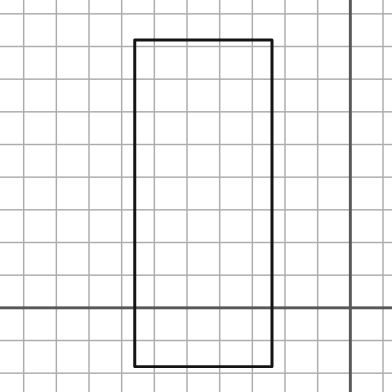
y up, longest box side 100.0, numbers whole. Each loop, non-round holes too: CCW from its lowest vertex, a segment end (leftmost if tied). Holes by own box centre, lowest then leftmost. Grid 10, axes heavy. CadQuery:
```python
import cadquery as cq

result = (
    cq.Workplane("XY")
    .moveTo(-66.0, -18.0)
    .lineTo(-24.0, -18.0)
    .lineTo(-24.0, 82.0)
    .lineTo(-66.0, 82.0)
    .close()
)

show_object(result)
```